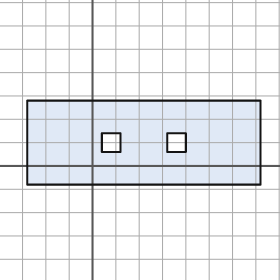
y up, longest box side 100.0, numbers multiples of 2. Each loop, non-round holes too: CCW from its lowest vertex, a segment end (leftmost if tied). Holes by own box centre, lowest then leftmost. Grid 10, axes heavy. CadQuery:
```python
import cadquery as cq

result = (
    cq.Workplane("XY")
    .moveTo(-28.0, -8.0)
    .lineTo(72.0, -8.0)
    .lineTo(72.0, 28.0)
    .lineTo(-28.0, 28.0)
    .close()
    .moveTo(4.0, 6.0)
    .lineTo(12.0, 6.0)
    .lineTo(12.0, 14.0)
    .lineTo(4.0, 14.0)
    .close()
    .moveTo(32.0, 6.0)
    .lineTo(40.0, 6.0)
    .lineTo(40.0, 14.0)
    .lineTo(32.0, 14.0)
    .close()
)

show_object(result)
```